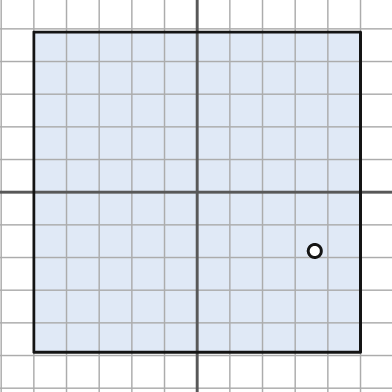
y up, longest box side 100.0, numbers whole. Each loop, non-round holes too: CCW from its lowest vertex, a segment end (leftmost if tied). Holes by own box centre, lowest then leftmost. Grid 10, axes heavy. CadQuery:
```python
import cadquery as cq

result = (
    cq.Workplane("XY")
    .moveTo(-50.0, -49.0)
    .lineTo(50.0, -49.0)
    .lineTo(50.0, 49.0)
    .lineTo(-50.0, 49.0)
    .close()
    .moveTo(36.0, -18.0)
    .circle(2.0)
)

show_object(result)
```